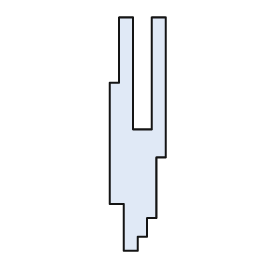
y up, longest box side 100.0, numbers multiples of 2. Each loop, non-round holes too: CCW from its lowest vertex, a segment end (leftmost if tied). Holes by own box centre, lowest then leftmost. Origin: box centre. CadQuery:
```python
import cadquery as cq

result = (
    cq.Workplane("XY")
    .moveTo(-6.0, -50.0)
    .lineTo(0.0, -50.0)
    .lineTo(0.0, -44.0)
    .lineTo(4.0, -44.0)
    .lineTo(4.0, -36.0)
    .lineTo(8.0, -36.0)
    .lineTo(8.0, -10.0)
    .lineTo(12.0, -10.0)
    .lineTo(12.0, 50.0)
    .lineTo(6.0, 50.0)
    .lineTo(6.0, 2.0)
    .lineTo(-2.0, 2.0)
    .lineTo(-2.0, 50.0)
    .lineTo(-8.0, 50.0)
    .lineTo(-8.0, 22.0)
    .lineTo(-12.0, 22.0)
    .lineTo(-12.0, -30.0)
    .lineTo(-6.0, -30.0)
    .close()
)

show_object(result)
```